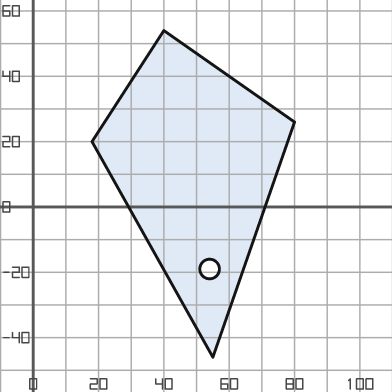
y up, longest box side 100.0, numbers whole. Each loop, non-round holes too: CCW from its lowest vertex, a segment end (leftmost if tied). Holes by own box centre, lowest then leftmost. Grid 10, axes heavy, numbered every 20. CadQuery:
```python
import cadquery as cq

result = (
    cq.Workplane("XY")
    .moveTo(55.0, -46.0)
    .lineTo(80.0, 26.0)
    .lineTo(40.0, 54.0)
    .lineTo(18.0, 20.0)
    .close()
    .moveTo(54.0, -19.0)
    .circle(3.0)
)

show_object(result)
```